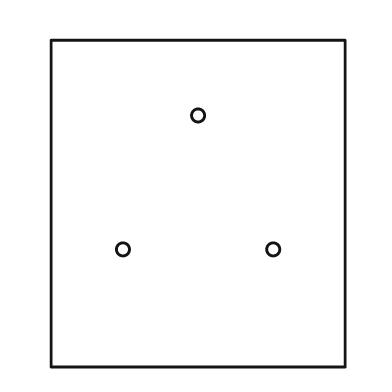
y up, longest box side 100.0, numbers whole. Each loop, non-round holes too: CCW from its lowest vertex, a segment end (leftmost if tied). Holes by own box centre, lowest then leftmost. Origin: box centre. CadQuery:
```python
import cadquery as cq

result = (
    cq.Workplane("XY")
    .moveTo(-45.0, -50.0)
    .lineTo(45.0, -50.0)
    .lineTo(45.0, 50.0)
    .lineTo(-45.0, 50.0)
    .close()
    .moveTo(-23.0, -14.0)
    .circle(2.0)
    .moveTo(23.0, -14.0)
    .circle(2.0)
    .moveTo(0.0, 27.0)
    .circle(2.0)
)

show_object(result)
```